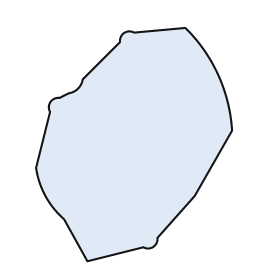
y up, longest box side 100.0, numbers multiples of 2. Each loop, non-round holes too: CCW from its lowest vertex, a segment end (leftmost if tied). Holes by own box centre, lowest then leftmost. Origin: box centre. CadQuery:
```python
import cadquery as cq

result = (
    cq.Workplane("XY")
    .moveTo(-20.0, -50.0)
    .lineTo(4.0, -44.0)
    .threePointArc((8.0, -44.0), (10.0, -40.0))
    .lineTo(26.0, -22.0)
    .lineTo(42.0, 6.0)
    .threePointArc((36.0, 30.0), (22.0, 50.0))
    .lineTo(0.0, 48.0)
    .threePointArc((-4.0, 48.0), (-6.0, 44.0))
    .lineTo(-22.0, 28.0)
    .threePointArc((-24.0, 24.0), (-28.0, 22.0))
    .lineTo(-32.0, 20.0)
    .threePointArc((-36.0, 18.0), (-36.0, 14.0))
    .lineTo(-42.0, -10.0)
    .threePointArc((-38.0, -22.0), (-30.0, -32.0))
    .close()
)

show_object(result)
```